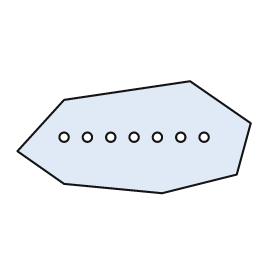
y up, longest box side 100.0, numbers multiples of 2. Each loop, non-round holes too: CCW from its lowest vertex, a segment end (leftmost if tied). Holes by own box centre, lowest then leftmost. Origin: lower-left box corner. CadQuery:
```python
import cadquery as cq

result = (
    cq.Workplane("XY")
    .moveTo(62.0, 0.0)
    .lineTo(94.0, 8.0)
    .lineTo(100.0, 30.0)
    .lineTo(74.0, 48.0)
    .lineTo(20.0, 40.0)
    .lineTo(0.0, 18.0)
    .lineTo(20.0, 4.0)
    .close()
    .moveTo(20.0, 24.0)
    .circle(2.0)
    .moveTo(30.0, 24.0)
    .circle(2.0)
    .moveTo(40.0, 24.0)
    .circle(2.0)
    .moveTo(50.0, 24.0)
    .circle(2.0)
    .moveTo(60.0, 24.0)
    .circle(2.0)
    .moveTo(70.0, 24.0)
    .circle(2.0)
    .moveTo(80.0, 24.0)
    .circle(2.0)
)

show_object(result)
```